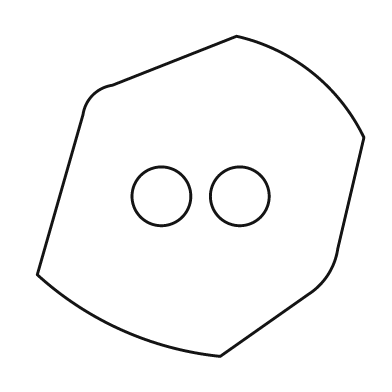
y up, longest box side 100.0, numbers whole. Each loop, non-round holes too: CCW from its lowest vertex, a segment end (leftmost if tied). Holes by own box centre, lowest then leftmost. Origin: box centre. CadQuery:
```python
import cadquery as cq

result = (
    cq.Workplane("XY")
    .moveTo(6.0, -49.0)
    .lineTo(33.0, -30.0)
    .threePointArc((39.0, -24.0), (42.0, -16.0))
    .lineTo(50.0, 18.0)
    .threePointArc((34.0, 38.0), (11.0, 49.0))
    .lineTo(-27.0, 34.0)
    .threePointArc((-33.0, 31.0), (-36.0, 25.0))
    .lineTo(-50.0, -24.0)
    .threePointArc((-24.0, -41.0), (6.0, -49.0))
    .close()
    .moveTo(-12.0, 0.0)
    .circle(9.0)
    .moveTo(12.0, 0.0)
    .circle(9.0)
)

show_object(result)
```